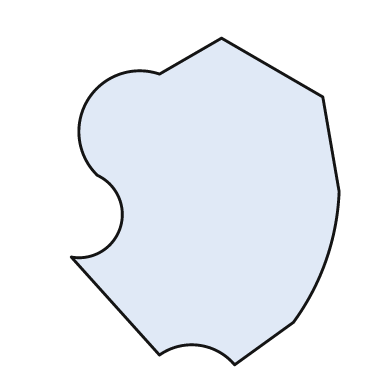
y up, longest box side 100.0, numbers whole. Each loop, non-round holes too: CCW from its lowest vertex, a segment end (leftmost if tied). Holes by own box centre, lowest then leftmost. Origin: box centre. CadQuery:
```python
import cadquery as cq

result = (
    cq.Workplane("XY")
    .moveTo(9.0, -50.0)
    .lineTo(27.0, -37.0)
    .threePointArc((37.0, -18.0), (41.0, 3.0))
    .lineTo(36.0, 32.0)
    .lineTo(5.0, 50.0)
    .lineTo(-14.0, 39.0)
    .threePointArc((-36.0, 31.0), (-33.0, 8.0))
    .threePointArc((-26.0, -8.0), (-41.0, -17.0))
    .lineTo(-14.0, -47.0)
    .threePointArc((-2.0, -44.0), (9.0, -50.0))
    .close()
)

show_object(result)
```